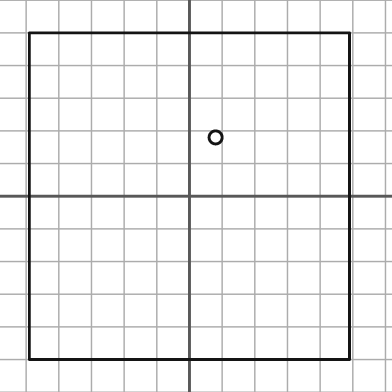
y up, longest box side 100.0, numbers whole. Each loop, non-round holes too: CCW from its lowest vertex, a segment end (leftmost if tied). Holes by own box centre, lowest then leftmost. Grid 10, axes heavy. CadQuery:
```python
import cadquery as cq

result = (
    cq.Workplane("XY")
    .moveTo(-49.0, -50.0)
    .lineTo(49.0, -50.0)
    .lineTo(49.0, 50.0)
    .lineTo(-49.0, 50.0)
    .close()
    .moveTo(8.0, 18.0)
    .circle(2.0)
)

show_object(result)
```